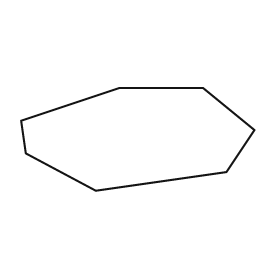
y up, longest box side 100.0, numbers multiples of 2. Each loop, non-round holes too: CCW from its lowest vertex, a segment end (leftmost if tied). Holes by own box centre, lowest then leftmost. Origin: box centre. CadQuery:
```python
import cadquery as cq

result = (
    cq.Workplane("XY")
    .moveTo(-18.0, -22.0)
    .lineTo(38.0, -14.0)
    .lineTo(50.0, 4.0)
    .lineTo(28.0, 22.0)
    .lineTo(-8.0, 22.0)
    .lineTo(-50.0, 8.0)
    .lineTo(-48.0, -6.0)
    .close()
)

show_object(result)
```